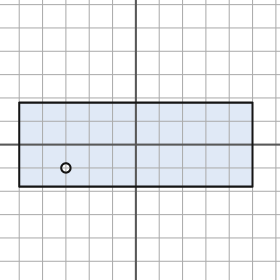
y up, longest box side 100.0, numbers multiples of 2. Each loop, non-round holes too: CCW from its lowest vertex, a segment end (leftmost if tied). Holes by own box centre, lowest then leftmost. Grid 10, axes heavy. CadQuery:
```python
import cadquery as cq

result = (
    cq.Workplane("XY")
    .moveTo(-50.0, -18.0)
    .lineTo(50.0, -18.0)
    .lineTo(50.0, 18.0)
    .lineTo(-50.0, 18.0)
    .close()
    .moveTo(-30.0, -10.0)
    .circle(2.0)
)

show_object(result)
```